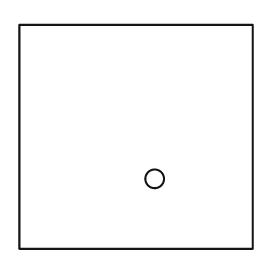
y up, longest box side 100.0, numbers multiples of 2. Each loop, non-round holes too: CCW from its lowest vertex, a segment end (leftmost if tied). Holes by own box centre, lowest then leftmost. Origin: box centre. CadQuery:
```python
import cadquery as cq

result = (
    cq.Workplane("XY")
    .moveTo(-50.0, -48.0)
    .lineTo(50.0, -48.0)
    .lineTo(50.0, 48.0)
    .lineTo(-50.0, 48.0)
    .close()
    .moveTo(8.0, -18.0)
    .circle(4.0)
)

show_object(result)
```